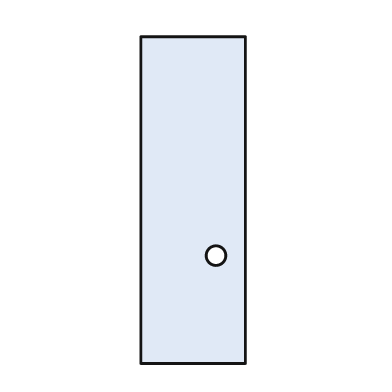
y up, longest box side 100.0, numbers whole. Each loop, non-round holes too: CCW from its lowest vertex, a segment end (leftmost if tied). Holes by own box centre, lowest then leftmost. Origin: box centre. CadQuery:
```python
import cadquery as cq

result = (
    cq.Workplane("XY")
    .moveTo(-16.0, -50.0)
    .lineTo(16.0, -50.0)
    .lineTo(16.0, 50.0)
    .lineTo(-16.0, 50.0)
    .close()
    .moveTo(7.0, -17.0)
    .circle(3.0)
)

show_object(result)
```